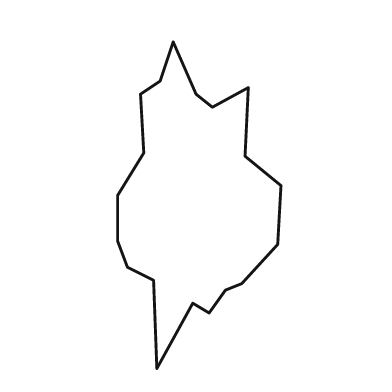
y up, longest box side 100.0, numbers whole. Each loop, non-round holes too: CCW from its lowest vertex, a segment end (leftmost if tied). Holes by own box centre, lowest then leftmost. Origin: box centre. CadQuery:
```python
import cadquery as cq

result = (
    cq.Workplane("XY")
    .moveTo(-13.0, -50.0)
    .lineTo(-2.0, -30.0)
    .lineTo(3.0, -33.0)
    .lineTo(8.0, -26.0)
    .lineTo(13.0, -24.0)
    .lineTo(24.0, -12.0)
    .lineTo(25.0, 6.0)
    .lineTo(14.0, 15.0)
    .lineTo(15.0, 36.0)
    .lineTo(4.0, 30.0)
    .lineTo(-1.0, 34.0)
    .lineTo(-8.0, 50.0)
    .lineTo(-12.0, 38.0)
    .lineTo(-18.0, 34.0)
    .lineTo(-17.0, 16.0)
    .lineTo(-25.0, 3.0)
    .lineTo(-25.0, -11.0)
    .lineTo(-22.0, -19.0)
    .lineTo(-14.0, -23.0)
    .close()
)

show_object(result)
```